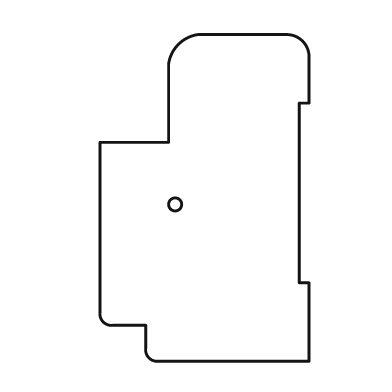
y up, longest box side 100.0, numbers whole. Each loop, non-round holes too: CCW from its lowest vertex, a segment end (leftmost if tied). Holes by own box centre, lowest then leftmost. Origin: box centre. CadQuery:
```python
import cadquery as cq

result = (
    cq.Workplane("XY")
    .moveTo(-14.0, -50.0)
    .lineTo(32.0, -50.0)
    .lineTo(32.0, -26.0)
    .lineTo(29.0, -26.0)
    .lineTo(29.0, 29.0)
    .lineTo(32.0, 29.0)
    .lineTo(32.0, 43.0)
    .threePointArc((30.0, 48.0), (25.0, 50.0))
    .lineTo(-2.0, 50.0)
    .threePointArc((-8.0, 47.0), (-11.0, 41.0))
    .lineTo(-11.0, 17.0)
    .lineTo(-32.0, 17.0)
    .lineTo(-32.0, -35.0)
    .threePointArc((-31.0, -38.0), (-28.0, -39.0))
    .lineTo(-18.0, -39.0)
    .lineTo(-18.0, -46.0)
    .threePointArc((-17.0, -49.0), (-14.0, -50.0))
    .close()
    .moveTo(-9.0, -2.0)
    .circle(2.0)
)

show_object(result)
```